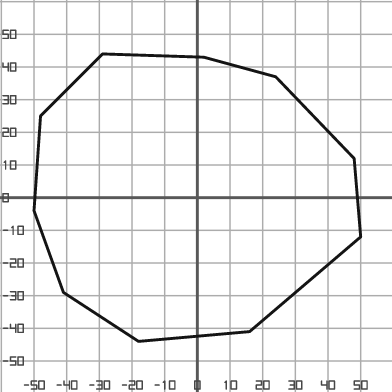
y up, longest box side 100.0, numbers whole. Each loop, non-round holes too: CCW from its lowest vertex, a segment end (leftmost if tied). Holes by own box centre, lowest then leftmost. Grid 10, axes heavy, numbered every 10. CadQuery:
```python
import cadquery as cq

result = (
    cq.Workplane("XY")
    .moveTo(-18.0, -44.0)
    .lineTo(16.0, -41.0)
    .lineTo(50.0, -12.0)
    .lineTo(48.0, 12.0)
    .lineTo(24.0, 37.0)
    .lineTo(2.0, 43.0)
    .lineTo(-29.0, 44.0)
    .lineTo(-48.0, 25.0)
    .lineTo(-50.0, -4.0)
    .lineTo(-41.0, -29.0)
    .close()
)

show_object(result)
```